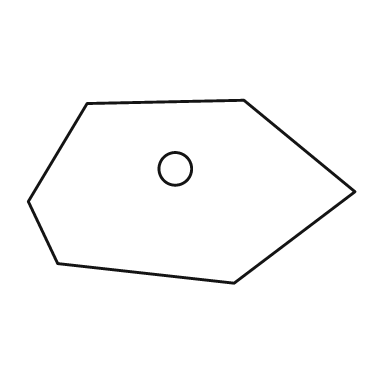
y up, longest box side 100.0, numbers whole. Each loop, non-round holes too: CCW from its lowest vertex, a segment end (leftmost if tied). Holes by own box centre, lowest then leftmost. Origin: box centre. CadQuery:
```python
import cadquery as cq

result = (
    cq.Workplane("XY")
    .moveTo(13.0, -28.0)
    .lineTo(50.0, 0.0)
    .lineTo(16.0, 28.0)
    .lineTo(-32.0, 27.0)
    .lineTo(-50.0, -3.0)
    .lineTo(-41.0, -22.0)
    .close()
    .moveTo(-5.0, 7.0)
    .circle(5.0)
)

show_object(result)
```